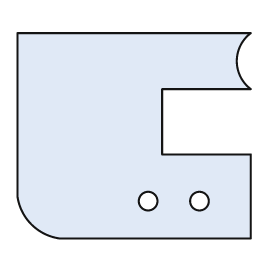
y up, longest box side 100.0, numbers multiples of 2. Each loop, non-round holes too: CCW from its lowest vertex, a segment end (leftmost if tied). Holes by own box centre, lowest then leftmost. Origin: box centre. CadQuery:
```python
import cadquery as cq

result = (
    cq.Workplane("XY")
    .moveTo(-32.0, -44.0)
    .lineTo(50.0, -44.0)
    .lineTo(50.0, -8.0)
    .lineTo(12.0, -8.0)
    .lineTo(12.0, 20.0)
    .lineTo(50.0, 20.0)
    .threePointArc((44.0, 32.0), (50.0, 44.0))
    .lineTo(-50.0, 44.0)
    .lineTo(-50.0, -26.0)
    .threePointArc((-44.0, -38.0), (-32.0, -44.0))
    .close()
    .moveTo(6.0, -28.0)
    .circle(4.0)
    .moveTo(28.0, -28.0)
    .circle(4.0)
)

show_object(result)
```